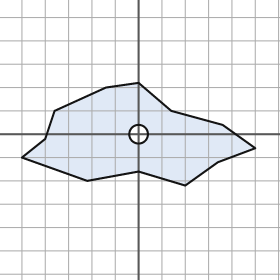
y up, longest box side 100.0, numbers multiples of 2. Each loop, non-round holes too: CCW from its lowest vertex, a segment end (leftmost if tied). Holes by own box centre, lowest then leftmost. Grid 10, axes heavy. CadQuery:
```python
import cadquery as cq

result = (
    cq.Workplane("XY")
    .moveTo(20.0, -22.0)
    .lineTo(34.0, -12.0)
    .lineTo(50.0, -6.0)
    .lineTo(36.0, 4.0)
    .lineTo(14.0, 10.0)
    .lineTo(0.0, 22.0)
    .lineTo(-14.0, 20.0)
    .lineTo(-36.0, 10.0)
    .lineTo(-40.0, -2.0)
    .lineTo(-50.0, -10.0)
    .lineTo(-22.0, -20.0)
    .lineTo(0.0, -16.0)
    .close()
    .moveTo(0.0, 0.0)
    .circle(4.0)
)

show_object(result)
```